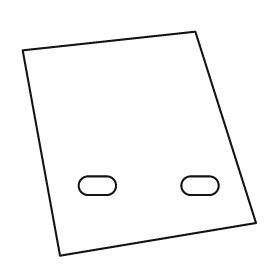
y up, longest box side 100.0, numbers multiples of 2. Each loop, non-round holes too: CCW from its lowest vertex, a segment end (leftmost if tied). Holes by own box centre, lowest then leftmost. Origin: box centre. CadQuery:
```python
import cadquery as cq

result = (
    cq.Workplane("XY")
    .moveTo(-34.0, -48.0)
    .lineTo(50.0, -34.0)
    .lineTo(24.0, 48.0)
    .lineTo(-50.0, 40.0)
    .close()
    .moveTo(-22.0, -22.0)
    .lineTo(-14.0, -22.0)
    .threePointArc((-10.0, -18.0), (-14.0, -14.0))
    .lineTo(-22.0, -14.0)
    .threePointArc((-26.0, -18.0), (-22.0, -22.0))
    .close()
    .moveTo(22.0, -22.0)
    .lineTo(30.0, -22.0)
    .threePointArc((34.0, -18.0), (30.0, -14.0))
    .lineTo(22.0, -14.0)
    .threePointArc((18.0, -18.0), (22.0, -22.0))
    .close()
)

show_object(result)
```